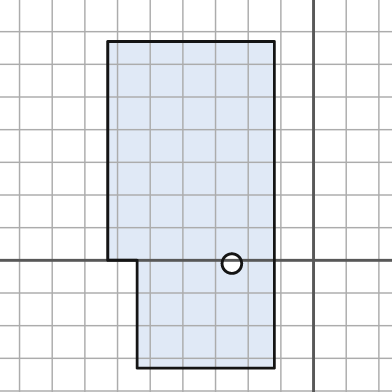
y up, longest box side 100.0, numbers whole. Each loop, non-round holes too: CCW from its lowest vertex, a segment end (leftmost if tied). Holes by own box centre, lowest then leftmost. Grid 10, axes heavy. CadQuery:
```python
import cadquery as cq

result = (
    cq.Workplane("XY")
    .moveTo(-54.0, -33.0)
    .lineTo(-12.0, -33.0)
    .lineTo(-12.0, 67.0)
    .lineTo(-63.0, 67.0)
    .lineTo(-63.0, 0.0)
    .lineTo(-54.0, 0.0)
    .close()
    .moveTo(-25.0, -1.0)
    .circle(3.0)
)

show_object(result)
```